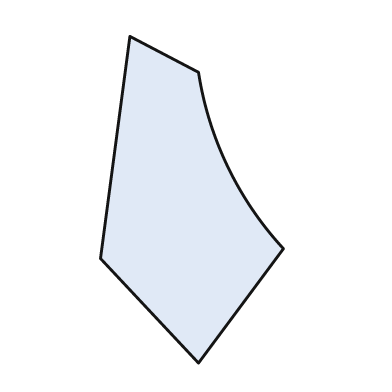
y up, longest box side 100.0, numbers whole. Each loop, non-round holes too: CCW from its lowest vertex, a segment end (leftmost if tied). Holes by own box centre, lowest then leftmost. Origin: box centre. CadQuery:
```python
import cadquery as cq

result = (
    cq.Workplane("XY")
    .moveTo(2.0, -50.0)
    .lineTo(28.0, -15.0)
    .threePointArc((11.0, 10.0), (2.0, 39.0))
    .lineTo(-19.0, 50.0)
    .lineTo(-28.0, -18.0)
    .close()
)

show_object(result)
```